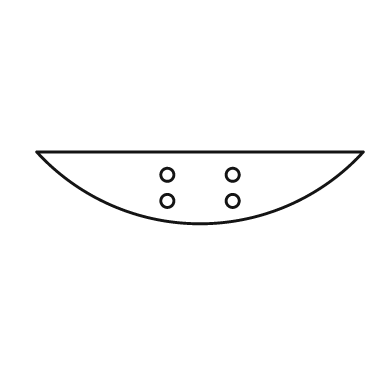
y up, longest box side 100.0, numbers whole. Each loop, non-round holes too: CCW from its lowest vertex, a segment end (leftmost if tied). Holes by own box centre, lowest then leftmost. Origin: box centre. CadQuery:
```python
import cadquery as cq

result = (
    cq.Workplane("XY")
    .moveTo(-50.0, 11.0)
    .threePointArc((0.0, -11.0), (50.0, 11.0))
    .close()
    .moveTo(-10.0, -4.0)
    .circle(2.0)
    .moveTo(10.0, -4.0)
    .circle(2.0)
    .moveTo(-10.0, 4.0)
    .circle(2.0)
    .moveTo(10.0, 4.0)
    .circle(2.0)
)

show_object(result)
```